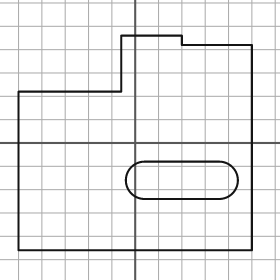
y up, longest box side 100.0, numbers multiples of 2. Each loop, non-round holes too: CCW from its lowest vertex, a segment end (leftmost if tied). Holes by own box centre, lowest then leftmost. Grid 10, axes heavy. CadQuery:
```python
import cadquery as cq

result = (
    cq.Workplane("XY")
    .moveTo(-50.0, -46.0)
    .lineTo(50.0, -46.0)
    .lineTo(50.0, 42.0)
    .lineTo(20.0, 42.0)
    .lineTo(20.0, 46.0)
    .lineTo(-6.0, 46.0)
    .lineTo(-6.0, 22.0)
    .lineTo(-50.0, 22.0)
    .close()
    .moveTo(4.0, -24.0)
    .lineTo(36.0, -24.0)
    .threePointArc((44.0, -16.0), (36.0, -8.0))
    .lineTo(4.0, -8.0)
    .threePointArc((-4.0, -16.0), (4.0, -24.0))
    .close()
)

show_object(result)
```